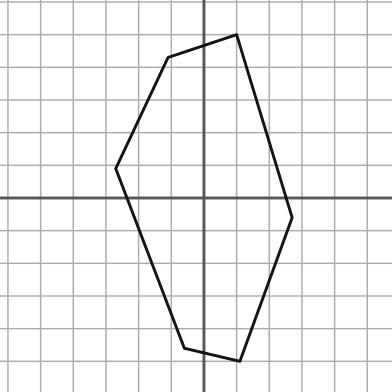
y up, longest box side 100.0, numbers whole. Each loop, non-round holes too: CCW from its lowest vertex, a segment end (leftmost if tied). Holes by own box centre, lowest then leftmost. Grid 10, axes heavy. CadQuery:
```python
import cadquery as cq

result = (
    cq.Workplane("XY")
    .moveTo(11.0, -50.0)
    .lineTo(27.0, -6.0)
    .lineTo(10.0, 50.0)
    .lineTo(-11.0, 43.0)
    .lineTo(-27.0, 9.0)
    .lineTo(-6.0, -46.0)
    .close()
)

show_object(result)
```